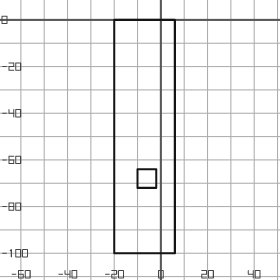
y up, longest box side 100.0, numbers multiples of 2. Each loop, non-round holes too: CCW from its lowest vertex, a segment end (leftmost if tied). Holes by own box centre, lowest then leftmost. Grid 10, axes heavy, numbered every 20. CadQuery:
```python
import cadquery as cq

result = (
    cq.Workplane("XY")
    .moveTo(-20.0, -100.0)
    .lineTo(6.0, -100.0)
    .lineTo(6.0, 0.0)
    .lineTo(-20.0, 0.0)
    .close()
    .moveTo(-10.0, -72.0)
    .lineTo(-2.0, -72.0)
    .lineTo(-2.0, -64.0)
    .lineTo(-10.0, -64.0)
    .close()
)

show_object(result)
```